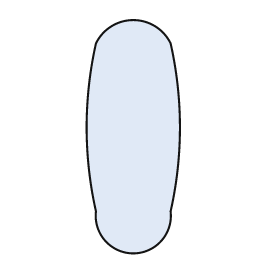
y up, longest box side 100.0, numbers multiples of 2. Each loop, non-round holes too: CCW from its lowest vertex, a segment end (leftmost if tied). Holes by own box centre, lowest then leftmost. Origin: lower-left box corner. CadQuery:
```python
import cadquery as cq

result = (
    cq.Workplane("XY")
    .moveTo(4.0, 18.0)
    .threePointArc((20.0, 0.0), (36.0, 18.0))
    .threePointArc((40.0, 54.0), (36.0, 90.0))
    .threePointArc((20.0, 100.0), (4.0, 90.0))
    .threePointArc((0.0, 54.0), (4.0, 18.0))
    .close()
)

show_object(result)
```